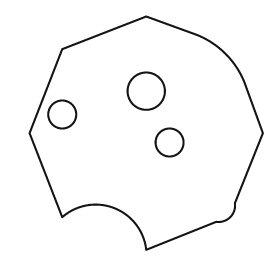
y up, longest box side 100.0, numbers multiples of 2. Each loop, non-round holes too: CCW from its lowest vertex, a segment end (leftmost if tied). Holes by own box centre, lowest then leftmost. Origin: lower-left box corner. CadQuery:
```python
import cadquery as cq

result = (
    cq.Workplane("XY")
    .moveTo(50.0, 0.0)
    .lineTo(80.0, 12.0)
    .threePointArc((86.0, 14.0), (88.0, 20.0))
    .lineTo(100.0, 50.0)
    .lineTo(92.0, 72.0)
    .threePointArc((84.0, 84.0), (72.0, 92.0))
    .lineTo(50.0, 100.0)
    .lineTo(14.0, 86.0)
    .lineTo(0.0, 50.0)
    .lineTo(14.0, 14.0)
    .threePointArc((36.0, 18.0), (50.0, 0.0))
    .close()
    .moveTo(60.0, 46.0)
    .circle(6.0)
    .moveTo(14.0, 58.0)
    .circle(6.0)
    .moveTo(50.0, 68.0)
    .circle(8.0)
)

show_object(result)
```